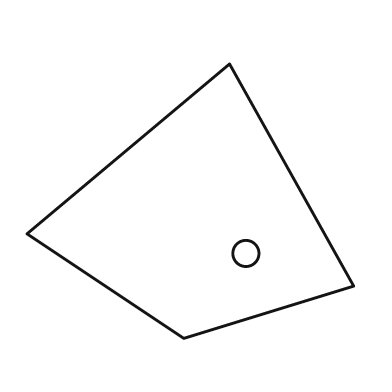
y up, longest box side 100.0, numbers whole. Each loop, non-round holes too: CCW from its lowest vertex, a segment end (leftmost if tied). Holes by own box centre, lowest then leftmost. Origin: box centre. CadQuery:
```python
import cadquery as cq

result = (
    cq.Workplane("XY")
    .moveTo(-2.0, -42.0)
    .lineTo(50.0, -26.0)
    .lineTo(12.0, 42.0)
    .lineTo(-50.0, -10.0)
    .close()
    .moveTo(17.0, -16.0)
    .circle(4.0)
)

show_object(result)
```